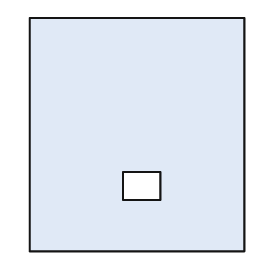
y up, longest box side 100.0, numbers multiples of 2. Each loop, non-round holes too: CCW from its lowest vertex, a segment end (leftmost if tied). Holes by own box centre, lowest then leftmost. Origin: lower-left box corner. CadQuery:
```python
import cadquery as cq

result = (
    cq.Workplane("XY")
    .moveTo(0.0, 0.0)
    .lineTo(92.0, 0.0)
    .lineTo(92.0, 100.0)
    .lineTo(0.0, 100.0)
    .close()
    .moveTo(40.0, 22.0)
    .lineTo(56.0, 22.0)
    .lineTo(56.0, 34.0)
    .lineTo(40.0, 34.0)
    .close()
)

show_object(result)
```